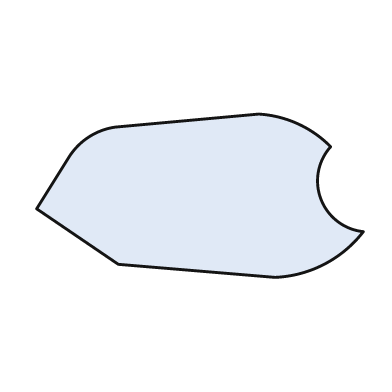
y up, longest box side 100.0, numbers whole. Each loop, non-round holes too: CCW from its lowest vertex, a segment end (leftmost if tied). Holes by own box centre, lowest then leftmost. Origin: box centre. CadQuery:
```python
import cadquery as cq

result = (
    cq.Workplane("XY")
    .moveTo(23.0, -25.0)
    .threePointArc((38.0, -21.0), (50.0, -11.0))
    .threePointArc((37.0, -1.0), (40.0, 15.0))
    .threePointArc((30.0, 22.0), (18.0, 25.0))
    .lineTo(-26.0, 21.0)
    .threePointArc((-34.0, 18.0), (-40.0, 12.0))
    .lineTo(-50.0, -4.0)
    .lineTo(-25.0, -21.0)
    .close()
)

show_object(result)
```